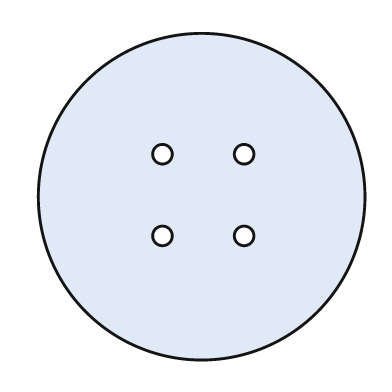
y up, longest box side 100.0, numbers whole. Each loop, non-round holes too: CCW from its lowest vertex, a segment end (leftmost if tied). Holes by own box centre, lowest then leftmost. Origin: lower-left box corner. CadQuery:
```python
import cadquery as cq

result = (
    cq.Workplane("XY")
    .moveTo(50.0, 50.0)
    .circle(50.0)
    .moveTo(38.0, 38.0)
    .circle(3.0)
    .moveTo(63.0, 38.0)
    .circle(3.0)
    .moveTo(38.0, 63.0)
    .circle(3.0)
    .moveTo(63.0, 63.0)
    .circle(3.0)
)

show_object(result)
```